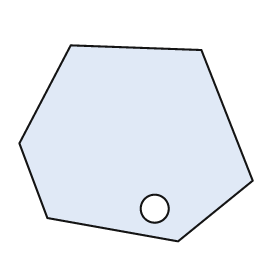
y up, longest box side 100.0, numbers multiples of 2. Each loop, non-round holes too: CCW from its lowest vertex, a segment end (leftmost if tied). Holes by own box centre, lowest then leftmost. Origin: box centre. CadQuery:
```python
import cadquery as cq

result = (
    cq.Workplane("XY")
    .moveTo(18.0, -42.0)
    .lineTo(50.0, -16.0)
    .lineTo(28.0, 40.0)
    .lineTo(-28.0, 42.0)
    .lineTo(-50.0, 0.0)
    .lineTo(-38.0, -32.0)
    .close()
    .moveTo(8.0, -28.0)
    .circle(6.0)
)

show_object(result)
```